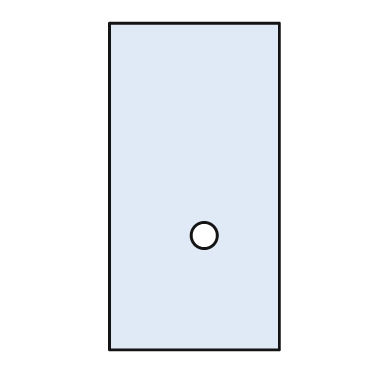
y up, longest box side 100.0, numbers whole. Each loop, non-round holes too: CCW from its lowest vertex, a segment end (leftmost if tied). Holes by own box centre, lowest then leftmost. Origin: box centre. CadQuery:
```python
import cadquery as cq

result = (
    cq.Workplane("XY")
    .moveTo(-26.0, -50.0)
    .lineTo(26.0, -50.0)
    .lineTo(26.0, 50.0)
    .lineTo(-26.0, 50.0)
    .close()
    .moveTo(3.0, -15.0)
    .circle(4.0)
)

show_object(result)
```